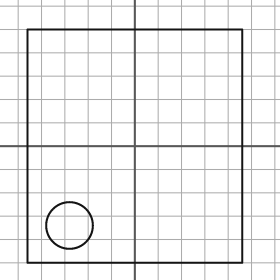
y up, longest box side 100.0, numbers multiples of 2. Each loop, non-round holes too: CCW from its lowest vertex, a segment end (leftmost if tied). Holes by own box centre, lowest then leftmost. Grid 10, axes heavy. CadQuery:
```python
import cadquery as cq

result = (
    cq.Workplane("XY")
    .moveTo(-46.0, -50.0)
    .lineTo(46.0, -50.0)
    .lineTo(46.0, 50.0)
    .lineTo(-46.0, 50.0)
    .close()
    .moveTo(-28.0, -34.0)
    .circle(10.0)
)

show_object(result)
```